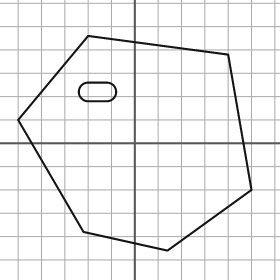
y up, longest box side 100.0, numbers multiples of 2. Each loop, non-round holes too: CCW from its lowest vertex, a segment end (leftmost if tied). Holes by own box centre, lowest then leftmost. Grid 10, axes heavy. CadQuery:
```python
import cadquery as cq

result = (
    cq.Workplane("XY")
    .moveTo(14.0, -46.0)
    .lineTo(50.0, -20.0)
    .lineTo(40.0, 38.0)
    .lineTo(-20.0, 46.0)
    .lineTo(-50.0, 10.0)
    .lineTo(-22.0, -38.0)
    .close()
    .moveTo(-20.0, 18.0)
    .lineTo(-12.0, 18.0)
    .threePointArc((-8.0, 22.0), (-12.0, 26.0))
    .lineTo(-20.0, 26.0)
    .threePointArc((-24.0, 22.0), (-20.0, 18.0))
    .close()
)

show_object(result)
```